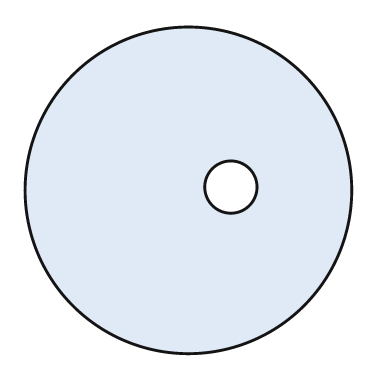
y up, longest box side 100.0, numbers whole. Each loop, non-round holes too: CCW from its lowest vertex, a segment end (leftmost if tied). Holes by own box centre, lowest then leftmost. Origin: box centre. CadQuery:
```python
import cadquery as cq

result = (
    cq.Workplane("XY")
    .moveTo(0.0, 0.0)
    .circle(50.0)
    .moveTo(13.0, 1.0)
    .circle(8.0)
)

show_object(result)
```